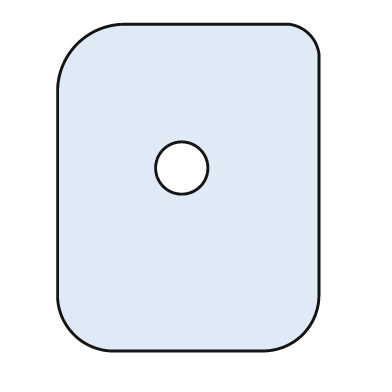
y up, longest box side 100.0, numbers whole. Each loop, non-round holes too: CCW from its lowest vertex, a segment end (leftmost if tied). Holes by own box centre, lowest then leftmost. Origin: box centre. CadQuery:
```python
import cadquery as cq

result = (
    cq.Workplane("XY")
    .moveTo(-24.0, -50.0)
    .lineTo(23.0, -50.0)
    .threePointArc((35.0, -45.0), (40.0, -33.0))
    .lineTo(40.0, 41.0)
    .threePointArc((37.0, 47.0), (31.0, 50.0))
    .lineTo(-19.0, 50.0)
    .threePointArc((-34.0, 44.0), (-40.0, 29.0))
    .lineTo(-40.0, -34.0)
    .threePointArc((-35.0, -45.0), (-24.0, -50.0))
    .close()
    .moveTo(-2.0, 6.0)
    .circle(8.0)
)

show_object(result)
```